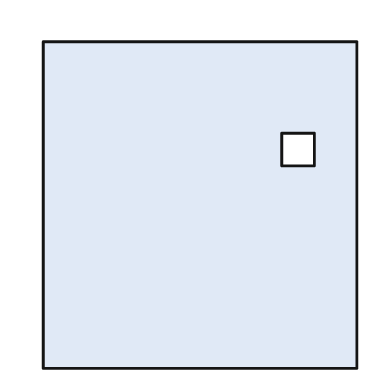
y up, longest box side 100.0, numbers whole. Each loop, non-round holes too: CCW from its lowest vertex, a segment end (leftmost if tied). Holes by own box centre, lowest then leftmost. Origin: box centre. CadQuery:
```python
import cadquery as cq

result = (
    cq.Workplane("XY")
    .moveTo(-48.0, -50.0)
    .lineTo(48.0, -50.0)
    .lineTo(48.0, 50.0)
    .lineTo(-48.0, 50.0)
    .close()
    .moveTo(25.0, 12.0)
    .lineTo(35.0, 12.0)
    .lineTo(35.0, 22.0)
    .lineTo(25.0, 22.0)
    .close()
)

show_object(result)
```